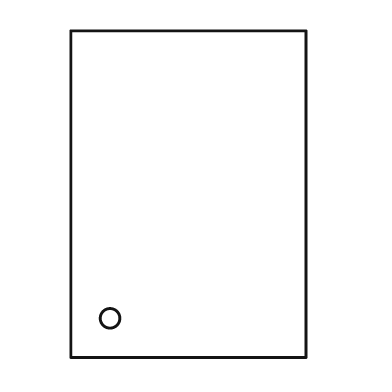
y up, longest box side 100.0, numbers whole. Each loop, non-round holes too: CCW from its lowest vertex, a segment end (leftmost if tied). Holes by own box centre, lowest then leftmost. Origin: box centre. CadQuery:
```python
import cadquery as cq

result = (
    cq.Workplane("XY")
    .moveTo(-36.0, -50.0)
    .lineTo(36.0, -50.0)
    .lineTo(36.0, 50.0)
    .lineTo(-36.0, 50.0)
    .close()
    .moveTo(-24.0, -38.0)
    .circle(3.0)
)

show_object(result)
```